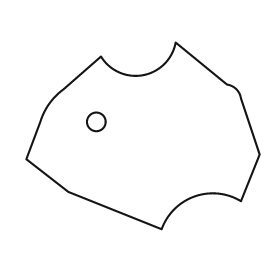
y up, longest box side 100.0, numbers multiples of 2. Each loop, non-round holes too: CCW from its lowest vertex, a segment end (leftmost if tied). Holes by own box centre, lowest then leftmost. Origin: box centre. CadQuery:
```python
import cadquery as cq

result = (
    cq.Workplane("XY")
    .moveTo(8.0, -40.0)
    .threePointArc((22.0, -26.0), (42.0, -28.0))
    .lineTo(50.0, -8.0)
    .lineTo(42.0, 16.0)
    .threePointArc((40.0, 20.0), (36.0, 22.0))
    .lineTo(14.0, 40.0)
    .threePointArc((0.0, 26.0), (-18.0, 34.0))
    .lineTo(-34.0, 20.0)
    .threePointArc((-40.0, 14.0), (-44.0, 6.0))
    .lineTo(-50.0, -10.0)
    .lineTo(-32.0, -24.0)
    .close()
    .moveTo(-20.0, 6.0)
    .circle(4.0)
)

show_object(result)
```